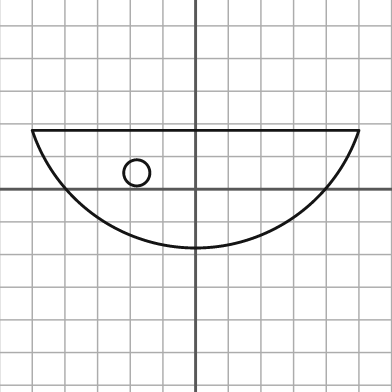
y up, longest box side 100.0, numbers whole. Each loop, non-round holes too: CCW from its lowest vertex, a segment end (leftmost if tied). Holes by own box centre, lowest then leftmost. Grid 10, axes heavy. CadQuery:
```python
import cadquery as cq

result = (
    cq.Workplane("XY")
    .moveTo(-50.0, 18.0)
    .threePointArc((0.0, -18.0), (50.0, 18.0))
    .close()
    .moveTo(-18.0, 5.0)
    .circle(4.0)
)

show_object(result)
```